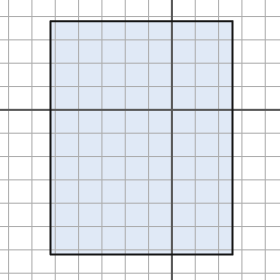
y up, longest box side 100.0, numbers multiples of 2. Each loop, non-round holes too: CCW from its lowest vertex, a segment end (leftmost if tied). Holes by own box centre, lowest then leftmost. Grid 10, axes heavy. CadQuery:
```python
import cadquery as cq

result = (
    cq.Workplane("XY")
    .moveTo(-52.0, -62.0)
    .lineTo(26.0, -62.0)
    .lineTo(26.0, 38.0)
    .lineTo(-52.0, 38.0)
    .close()
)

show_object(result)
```